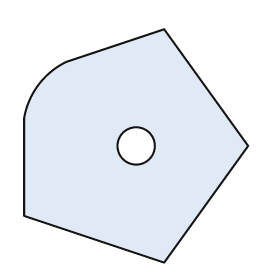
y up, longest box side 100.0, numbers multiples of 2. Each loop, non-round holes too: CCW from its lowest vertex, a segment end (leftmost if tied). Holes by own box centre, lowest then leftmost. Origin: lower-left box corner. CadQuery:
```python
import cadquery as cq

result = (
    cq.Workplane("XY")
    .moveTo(60.0, 0.0)
    .lineTo(96.0, 50.0)
    .lineTo(60.0, 100.0)
    .lineTo(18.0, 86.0)
    .threePointArc((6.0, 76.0), (0.0, 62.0))
    .lineTo(0.0, 20.0)
    .close()
    .moveTo(48.0, 50.0)
    .circle(8.0)
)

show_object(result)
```